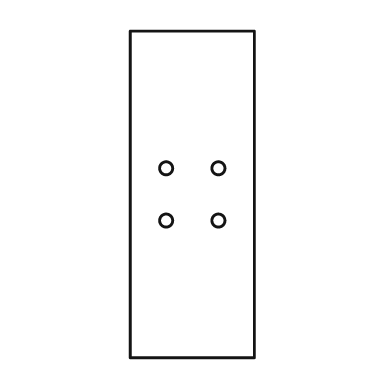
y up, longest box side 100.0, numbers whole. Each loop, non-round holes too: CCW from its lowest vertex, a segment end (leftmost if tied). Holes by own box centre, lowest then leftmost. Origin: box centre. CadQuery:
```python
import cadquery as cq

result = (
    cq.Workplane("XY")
    .moveTo(-19.0, -50.0)
    .lineTo(19.0, -50.0)
    .lineTo(19.0, 50.0)
    .lineTo(-19.0, 50.0)
    .close()
    .moveTo(-8.0, -8.0)
    .circle(2.0)
    .moveTo(8.0, -8.0)
    .circle(2.0)
    .moveTo(-8.0, 8.0)
    .circle(2.0)
    .moveTo(8.0, 8.0)
    .circle(2.0)
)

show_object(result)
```